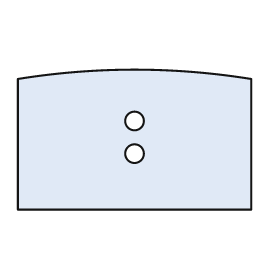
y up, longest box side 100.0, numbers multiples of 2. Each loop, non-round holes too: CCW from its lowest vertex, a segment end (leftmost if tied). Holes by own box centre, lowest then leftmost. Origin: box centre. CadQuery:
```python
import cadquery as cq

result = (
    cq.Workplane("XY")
    .moveTo(-50.0, -30.0)
    .lineTo(50.0, -30.0)
    .lineTo(50.0, 26.0)
    .threePointArc((0.0, 30.0), (-50.0, 26.0))
    .close()
    .moveTo(0.0, -6.0)
    .circle(4.0)
    .moveTo(0.0, 8.0)
    .circle(4.0)
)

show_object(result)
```